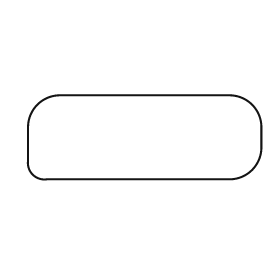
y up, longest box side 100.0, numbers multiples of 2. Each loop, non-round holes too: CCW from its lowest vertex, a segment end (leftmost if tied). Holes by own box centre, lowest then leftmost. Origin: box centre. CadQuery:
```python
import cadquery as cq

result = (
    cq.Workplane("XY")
    .moveTo(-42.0, -18.0)
    .lineTo(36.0, -18.0)
    .threePointArc((46.0, -14.0), (50.0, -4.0))
    .lineTo(50.0, 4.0)
    .threePointArc((46.0, 14.0), (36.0, 18.0))
    .lineTo(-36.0, 18.0)
    .threePointArc((-46.0, 14.0), (-50.0, 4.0))
    .lineTo(-50.0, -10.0)
    .threePointArc((-48.0, -16.0), (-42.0, -18.0))
    .close()
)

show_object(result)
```